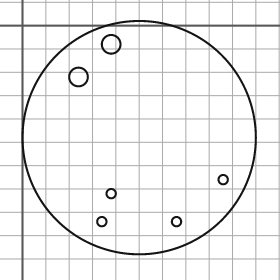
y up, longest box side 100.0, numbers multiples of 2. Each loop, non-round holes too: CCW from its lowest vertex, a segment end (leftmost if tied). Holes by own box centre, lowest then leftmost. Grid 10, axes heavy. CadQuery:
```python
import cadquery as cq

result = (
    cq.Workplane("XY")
    .moveTo(50.0, -48.0)
    .circle(50.0)
    .moveTo(34.0, -84.0)
    .circle(2.0)
    .moveTo(66.0, -84.0)
    .circle(2.0)
    .moveTo(38.0, -72.0)
    .circle(2.0)
    .moveTo(86.0, -66.0)
    .circle(2.0)
    .moveTo(24.0, -22.0)
    .circle(4.0)
    .moveTo(38.0, -8.0)
    .circle(4.0)
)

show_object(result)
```